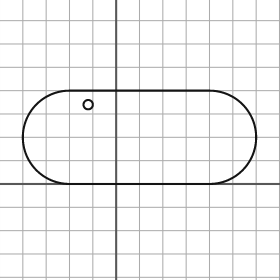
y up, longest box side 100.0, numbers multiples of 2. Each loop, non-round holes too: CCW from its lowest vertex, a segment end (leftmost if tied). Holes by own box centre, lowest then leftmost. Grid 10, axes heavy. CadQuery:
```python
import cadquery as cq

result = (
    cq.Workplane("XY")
    .moveTo(-20.0, 0.0)
    .lineTo(40.0, 0.0)
    .threePointArc((60.0, 20.0), (40.0, 40.0))
    .lineTo(-20.0, 40.0)
    .threePointArc((-40.0, 20.0), (-20.0, 0.0))
    .close()
    .moveTo(-12.0, 34.0)
    .circle(2.0)
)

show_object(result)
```